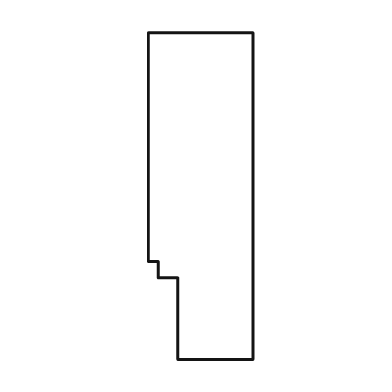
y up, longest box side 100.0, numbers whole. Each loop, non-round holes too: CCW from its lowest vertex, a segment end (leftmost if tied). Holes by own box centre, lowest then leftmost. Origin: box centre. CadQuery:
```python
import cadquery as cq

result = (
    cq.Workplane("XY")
    .moveTo(-7.0, -50.0)
    .lineTo(16.0, -50.0)
    .lineTo(16.0, 50.0)
    .lineTo(-16.0, 50.0)
    .lineTo(-16.0, -20.0)
    .lineTo(-13.0, -20.0)
    .lineTo(-13.0, -25.0)
    .lineTo(-7.0, -25.0)
    .close()
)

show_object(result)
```